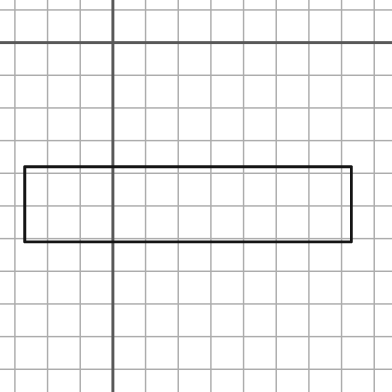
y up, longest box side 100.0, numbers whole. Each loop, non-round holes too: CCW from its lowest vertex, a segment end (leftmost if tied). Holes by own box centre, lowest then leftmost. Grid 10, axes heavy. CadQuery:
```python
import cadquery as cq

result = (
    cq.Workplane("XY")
    .moveTo(-27.0, -61.0)
    .lineTo(73.0, -61.0)
    .lineTo(73.0, -38.0)
    .lineTo(-27.0, -38.0)
    .close()
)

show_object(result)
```